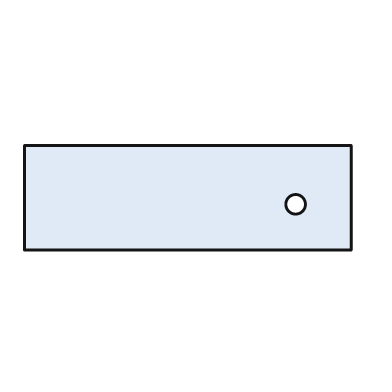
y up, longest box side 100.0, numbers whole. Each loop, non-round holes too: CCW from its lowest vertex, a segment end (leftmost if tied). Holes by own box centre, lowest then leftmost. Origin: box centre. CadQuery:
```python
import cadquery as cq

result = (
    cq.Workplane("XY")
    .moveTo(-50.0, -16.0)
    .lineTo(50.0, -16.0)
    .lineTo(50.0, 16.0)
    .lineTo(-50.0, 16.0)
    .close()
    .moveTo(33.0, -2.0)
    .circle(3.0)
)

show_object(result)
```